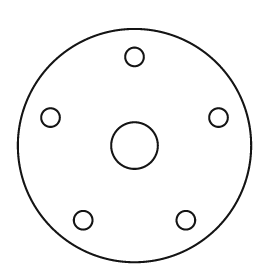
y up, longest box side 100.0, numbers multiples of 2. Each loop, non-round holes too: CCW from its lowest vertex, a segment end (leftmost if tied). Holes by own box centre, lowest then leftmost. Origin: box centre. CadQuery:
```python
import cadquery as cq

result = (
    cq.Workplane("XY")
    .moveTo(0.0, 0.0)
    .circle(50.0)
    .moveTo(-22.0, -32.0)
    .circle(4.0)
    .moveTo(22.0, -32.0)
    .circle(4.0)
    .moveTo(0.0, 0.0)
    .circle(10.0)
    .moveTo(-36.0, 12.0)
    .circle(4.0)
    .moveTo(36.0, 12.0)
    .circle(4.0)
    .moveTo(0.0, 38.0)
    .circle(4.0)
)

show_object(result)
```